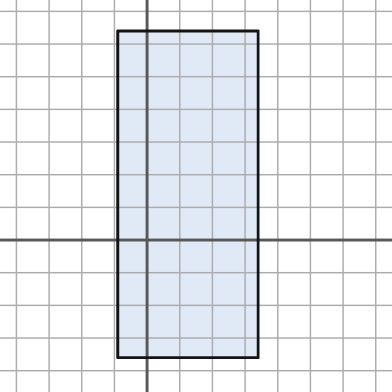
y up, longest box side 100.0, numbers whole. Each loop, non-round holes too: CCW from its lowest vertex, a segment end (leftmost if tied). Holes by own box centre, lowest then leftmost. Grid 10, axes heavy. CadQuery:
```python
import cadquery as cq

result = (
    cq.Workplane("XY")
    .moveTo(-9.0, -36.0)
    .lineTo(34.0, -36.0)
    .lineTo(34.0, 64.0)
    .lineTo(-9.0, 64.0)
    .close()
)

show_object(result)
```